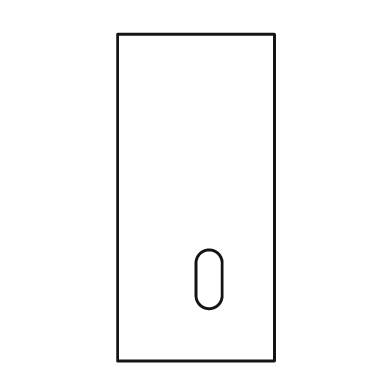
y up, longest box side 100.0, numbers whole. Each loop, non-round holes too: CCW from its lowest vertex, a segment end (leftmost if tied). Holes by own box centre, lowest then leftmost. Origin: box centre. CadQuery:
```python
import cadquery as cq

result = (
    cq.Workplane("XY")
    .moveTo(-24.0, -50.0)
    .lineTo(24.0, -50.0)
    .lineTo(24.0, 50.0)
    .lineTo(-24.0, 50.0)
    .close()
    .moveTo(0.0, -30.0)
    .threePointArc((4.0, -34.0), (8.0, -30.0))
    .lineTo(8.0, -20.0)
    .threePointArc((4.0, -16.0), (0.0, -20.0))
    .close()
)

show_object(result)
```